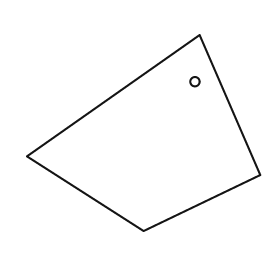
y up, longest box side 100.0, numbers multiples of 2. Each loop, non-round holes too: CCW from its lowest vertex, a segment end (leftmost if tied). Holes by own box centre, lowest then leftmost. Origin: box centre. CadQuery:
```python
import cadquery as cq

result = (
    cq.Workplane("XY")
    .moveTo(0.0, -42.0)
    .lineTo(50.0, -18.0)
    .lineTo(24.0, 42.0)
    .lineTo(-50.0, -10.0)
    .close()
    .moveTo(22.0, 22.0)
    .circle(2.0)
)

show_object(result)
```